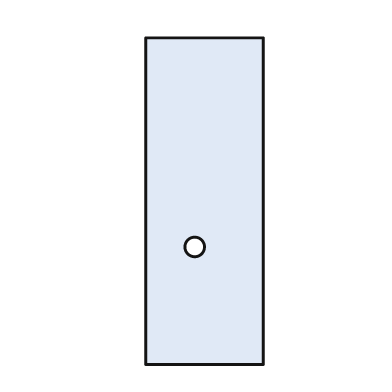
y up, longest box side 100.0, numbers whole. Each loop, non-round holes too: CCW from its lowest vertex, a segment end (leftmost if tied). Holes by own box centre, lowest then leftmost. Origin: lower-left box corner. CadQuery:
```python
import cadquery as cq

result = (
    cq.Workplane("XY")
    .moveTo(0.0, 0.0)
    .lineTo(36.0, 0.0)
    .lineTo(36.0, 100.0)
    .lineTo(0.0, 100.0)
    .close()
    .moveTo(15.0, 36.0)
    .circle(3.0)
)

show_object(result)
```